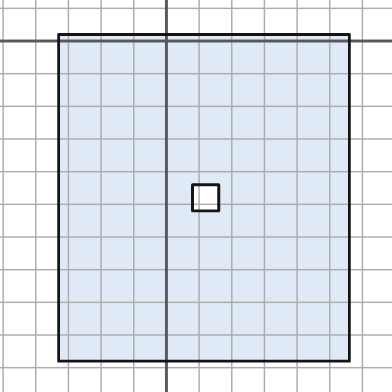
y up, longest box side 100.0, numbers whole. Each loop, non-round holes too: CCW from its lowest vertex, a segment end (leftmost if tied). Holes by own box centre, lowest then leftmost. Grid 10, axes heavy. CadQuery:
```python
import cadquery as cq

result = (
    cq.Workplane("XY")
    .moveTo(-33.0, -98.0)
    .lineTo(56.0, -98.0)
    .lineTo(56.0, 2.0)
    .lineTo(-33.0, 2.0)
    .close()
    .moveTo(8.0, -52.0)
    .lineTo(16.0, -52.0)
    .lineTo(16.0, -44.0)
    .lineTo(8.0, -44.0)
    .close()
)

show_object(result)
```